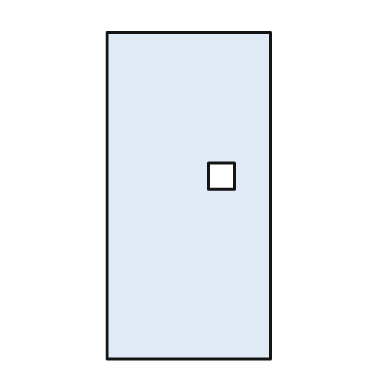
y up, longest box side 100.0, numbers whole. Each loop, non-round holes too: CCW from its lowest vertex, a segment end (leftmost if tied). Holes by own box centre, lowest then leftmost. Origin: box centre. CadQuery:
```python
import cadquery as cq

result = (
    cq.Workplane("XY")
    .moveTo(-25.0, -50.0)
    .lineTo(25.0, -50.0)
    .lineTo(25.0, 50.0)
    .lineTo(-25.0, 50.0)
    .close()
    .moveTo(6.0, 2.0)
    .lineTo(14.0, 2.0)
    .lineTo(14.0, 10.0)
    .lineTo(6.0, 10.0)
    .close()
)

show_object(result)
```